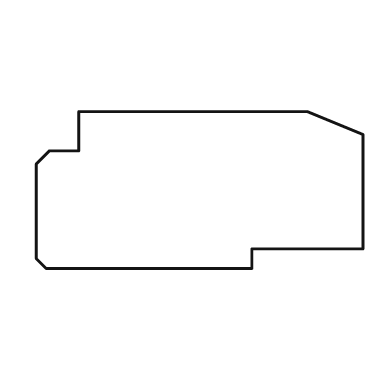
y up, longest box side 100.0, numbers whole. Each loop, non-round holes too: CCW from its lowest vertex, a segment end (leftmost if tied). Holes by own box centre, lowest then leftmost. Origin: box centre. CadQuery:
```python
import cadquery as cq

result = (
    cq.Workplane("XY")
    .moveTo(-47.0, -24.0)
    .lineTo(16.0, -24.0)
    .lineTo(16.0, -18.0)
    .lineTo(50.0, -18.0)
    .lineTo(50.0, 17.0)
    .lineTo(33.0, 24.0)
    .lineTo(-37.0, 24.0)
    .lineTo(-37.0, 12.0)
    .lineTo(-46.0, 12.0)
    .lineTo(-50.0, 8.0)
    .lineTo(-50.0, -21.0)
    .close()
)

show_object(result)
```